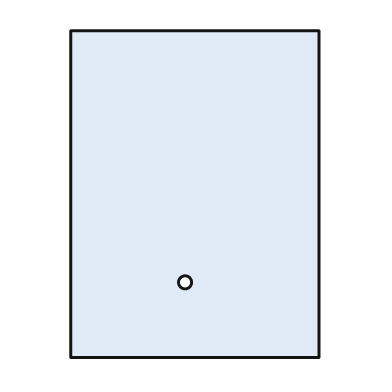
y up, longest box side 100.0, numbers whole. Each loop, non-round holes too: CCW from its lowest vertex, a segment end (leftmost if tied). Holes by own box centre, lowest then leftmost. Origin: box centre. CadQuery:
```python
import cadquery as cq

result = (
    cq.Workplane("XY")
    .moveTo(-38.0, -50.0)
    .lineTo(38.0, -50.0)
    .lineTo(38.0, 50.0)
    .lineTo(-38.0, 50.0)
    .close()
    .moveTo(-3.0, -27.0)
    .circle(2.0)
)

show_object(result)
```